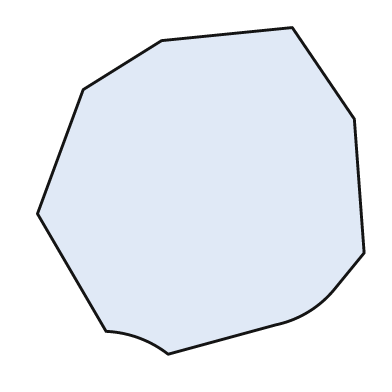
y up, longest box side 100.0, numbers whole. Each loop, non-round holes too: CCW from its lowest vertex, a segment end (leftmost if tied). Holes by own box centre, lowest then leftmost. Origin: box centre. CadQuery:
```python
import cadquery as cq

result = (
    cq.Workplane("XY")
    .moveTo(-10.0, -50.0)
    .lineTo(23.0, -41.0)
    .threePointArc((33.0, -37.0), (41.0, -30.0))
    .lineTo(50.0, -19.0)
    .lineTo(47.0, 22.0)
    .lineTo(28.0, 50.0)
    .lineTo(-12.0, 46.0)
    .lineTo(-36.0, 31.0)
    .lineTo(-50.0, -7.0)
    .lineTo(-29.0, -43.0)
    .threePointArc((-19.0, -45.0), (-10.0, -50.0))
    .close()
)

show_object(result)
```